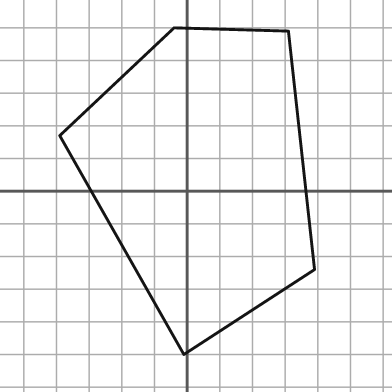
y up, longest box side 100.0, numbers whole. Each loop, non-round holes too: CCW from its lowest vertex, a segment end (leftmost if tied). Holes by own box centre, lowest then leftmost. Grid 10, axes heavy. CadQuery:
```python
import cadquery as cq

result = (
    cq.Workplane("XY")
    .moveTo(-1.0, -50.0)
    .lineTo(39.0, -24.0)
    .lineTo(31.0, 49.0)
    .lineTo(-4.0, 50.0)
    .lineTo(-39.0, 17.0)
    .close()
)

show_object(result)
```